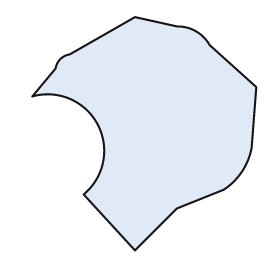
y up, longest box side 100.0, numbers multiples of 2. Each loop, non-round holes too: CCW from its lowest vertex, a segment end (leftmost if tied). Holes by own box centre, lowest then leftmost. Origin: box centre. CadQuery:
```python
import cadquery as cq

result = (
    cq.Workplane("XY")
    .moveTo(-4.0, -50.0)
    .lineTo(14.0, -32.0)
    .lineTo(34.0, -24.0)
    .threePointArc((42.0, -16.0), (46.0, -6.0))
    .lineTo(48.0, 20.0)
    .lineTo(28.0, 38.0)
    .threePointArc((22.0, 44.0), (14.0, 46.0))
    .lineTo(-4.0, 50.0)
    .lineTo(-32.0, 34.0)
    .threePointArc((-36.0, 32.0), (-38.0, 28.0))
    .lineTo(-48.0, 16.0)
    .threePointArc((-20.0, 4.0), (-26.0, -26.0))
    .close()
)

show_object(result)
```